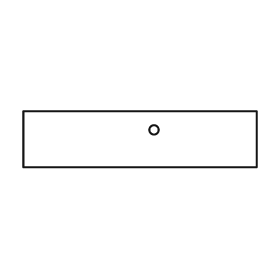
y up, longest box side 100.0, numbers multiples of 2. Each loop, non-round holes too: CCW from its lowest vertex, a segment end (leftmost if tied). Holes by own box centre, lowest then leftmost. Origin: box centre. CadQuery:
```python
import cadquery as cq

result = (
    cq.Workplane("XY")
    .moveTo(-50.0, -12.0)
    .lineTo(50.0, -12.0)
    .lineTo(50.0, 12.0)
    .lineTo(-50.0, 12.0)
    .close()
    .moveTo(6.0, 4.0)
    .circle(2.0)
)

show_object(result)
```